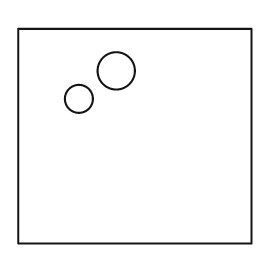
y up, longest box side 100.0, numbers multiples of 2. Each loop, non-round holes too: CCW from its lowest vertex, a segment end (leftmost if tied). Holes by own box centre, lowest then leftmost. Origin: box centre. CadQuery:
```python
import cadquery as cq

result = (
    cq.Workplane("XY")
    .moveTo(-50.0, -46.0)
    .lineTo(50.0, -46.0)
    .lineTo(50.0, 46.0)
    .lineTo(-50.0, 46.0)
    .close()
    .moveTo(-24.0, 16.0)
    .circle(6.0)
    .moveTo(-8.0, 28.0)
    .circle(8.0)
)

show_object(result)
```